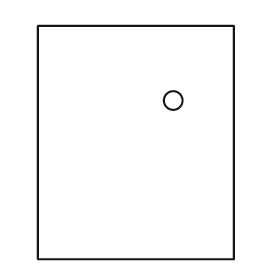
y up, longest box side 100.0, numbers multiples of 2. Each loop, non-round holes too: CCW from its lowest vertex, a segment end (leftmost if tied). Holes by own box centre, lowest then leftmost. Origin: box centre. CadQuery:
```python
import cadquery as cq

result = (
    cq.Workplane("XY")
    .moveTo(-42.0, -50.0)
    .lineTo(42.0, -50.0)
    .lineTo(42.0, 50.0)
    .lineTo(-42.0, 50.0)
    .close()
    .moveTo(16.0, 18.0)
    .circle(4.0)
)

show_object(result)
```